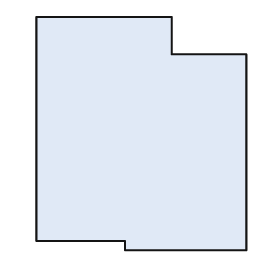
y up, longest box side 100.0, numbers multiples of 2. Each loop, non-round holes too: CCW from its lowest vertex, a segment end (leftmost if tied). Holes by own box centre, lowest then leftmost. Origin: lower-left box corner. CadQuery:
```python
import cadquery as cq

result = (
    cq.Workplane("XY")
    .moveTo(38.0, 0.0)
    .lineTo(90.0, 0.0)
    .lineTo(90.0, 84.0)
    .lineTo(58.0, 84.0)
    .lineTo(58.0, 100.0)
    .lineTo(0.0, 100.0)
    .lineTo(0.0, 4.0)
    .lineTo(38.0, 4.0)
    .close()
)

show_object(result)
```